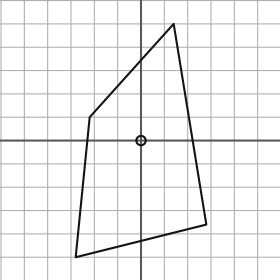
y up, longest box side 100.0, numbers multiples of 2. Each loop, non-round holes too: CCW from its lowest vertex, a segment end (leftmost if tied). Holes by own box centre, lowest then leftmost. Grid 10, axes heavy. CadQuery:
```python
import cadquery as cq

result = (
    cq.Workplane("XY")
    .moveTo(-28.0, -50.0)
    .lineTo(28.0, -36.0)
    .lineTo(14.0, 50.0)
    .lineTo(-22.0, 10.0)
    .close()
    .moveTo(0.0, 0.0)
    .circle(2.0)
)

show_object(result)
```